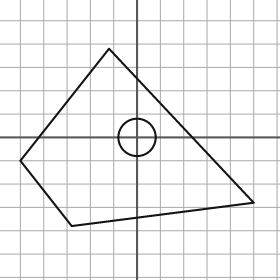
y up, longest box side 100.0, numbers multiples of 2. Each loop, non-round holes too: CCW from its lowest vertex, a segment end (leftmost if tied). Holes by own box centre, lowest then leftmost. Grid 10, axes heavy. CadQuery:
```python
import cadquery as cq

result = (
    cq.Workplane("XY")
    .moveTo(-28.0, -38.0)
    .lineTo(50.0, -28.0)
    .lineTo(-12.0, 38.0)
    .lineTo(-50.0, -10.0)
    .close()
    .moveTo(0.0, 0.0)
    .circle(8.0)
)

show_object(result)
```